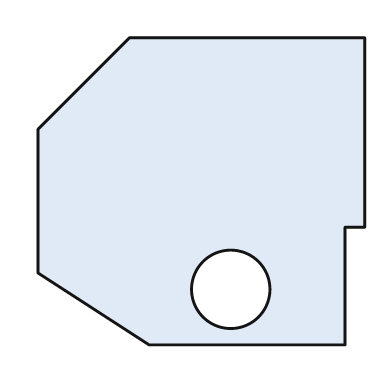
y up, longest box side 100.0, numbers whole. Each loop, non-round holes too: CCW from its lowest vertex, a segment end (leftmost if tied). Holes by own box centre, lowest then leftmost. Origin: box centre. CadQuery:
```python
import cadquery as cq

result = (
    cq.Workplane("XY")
    .moveTo(-16.0, -47.0)
    .lineTo(44.0, -47.0)
    .lineTo(44.0, -11.0)
    .lineTo(50.0, -11.0)
    .lineTo(50.0, 47.0)
    .lineTo(-22.0, 47.0)
    .lineTo(-50.0, 19.0)
    .lineTo(-50.0, -25.0)
    .close()
    .moveTo(9.0, -30.0)
    .circle(12.0)
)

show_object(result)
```